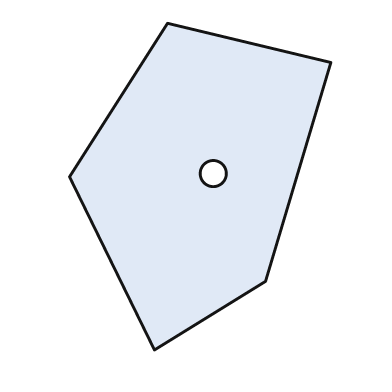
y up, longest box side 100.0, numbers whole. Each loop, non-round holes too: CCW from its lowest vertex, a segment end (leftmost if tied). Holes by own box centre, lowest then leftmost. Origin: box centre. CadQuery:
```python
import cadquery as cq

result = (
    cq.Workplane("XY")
    .moveTo(-14.0, -50.0)
    .lineTo(20.0, -29.0)
    .lineTo(40.0, 38.0)
    .lineTo(-10.0, 50.0)
    .lineTo(-40.0, 3.0)
    .close()
    .moveTo(4.0, 4.0)
    .circle(4.0)
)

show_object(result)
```